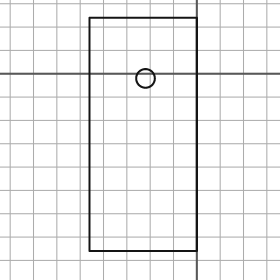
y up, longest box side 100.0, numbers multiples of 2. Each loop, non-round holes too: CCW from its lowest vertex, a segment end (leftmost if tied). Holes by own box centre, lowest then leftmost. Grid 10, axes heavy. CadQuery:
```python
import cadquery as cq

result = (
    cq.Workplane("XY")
    .moveTo(-46.0, -76.0)
    .lineTo(0.0, -76.0)
    .lineTo(0.0, 24.0)
    .lineTo(-46.0, 24.0)
    .close()
    .moveTo(-22.0, -2.0)
    .circle(4.0)
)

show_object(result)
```